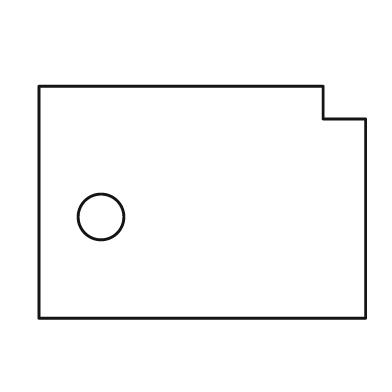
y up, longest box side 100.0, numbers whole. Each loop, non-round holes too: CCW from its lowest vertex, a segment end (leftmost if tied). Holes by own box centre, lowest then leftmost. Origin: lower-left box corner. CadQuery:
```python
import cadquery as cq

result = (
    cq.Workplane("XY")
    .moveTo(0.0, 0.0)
    .lineTo(100.0, 0.0)
    .lineTo(100.0, 61.0)
    .lineTo(87.0, 61.0)
    .lineTo(87.0, 71.0)
    .lineTo(0.0, 71.0)
    .close()
    .moveTo(19.0, 31.0)
    .circle(7.0)
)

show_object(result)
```